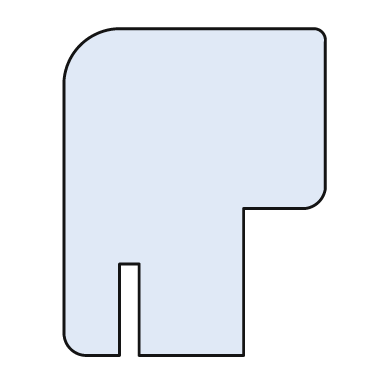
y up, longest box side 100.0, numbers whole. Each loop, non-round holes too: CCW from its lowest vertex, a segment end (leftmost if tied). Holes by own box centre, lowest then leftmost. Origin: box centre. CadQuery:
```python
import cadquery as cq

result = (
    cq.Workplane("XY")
    .moveTo(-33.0, -50.0)
    .lineTo(-23.0, -50.0)
    .lineTo(-23.0, -22.0)
    .lineTo(-17.0, -22.0)
    .lineTo(-17.0, -50.0)
    .lineTo(15.0, -50.0)
    .lineTo(15.0, -5.0)
    .lineTo(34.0, -5.0)
    .threePointArc((38.0, -3.0), (40.0, 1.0))
    .lineTo(40.0, 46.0)
    .threePointArc((39.0, 49.0), (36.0, 50.0))
    .lineTo(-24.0, 50.0)
    .threePointArc((-35.0, 45.0), (-40.0, 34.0))
    .lineTo(-40.0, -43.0)
    .threePointArc((-38.0, -48.0), (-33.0, -50.0))
    .close()
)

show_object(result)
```